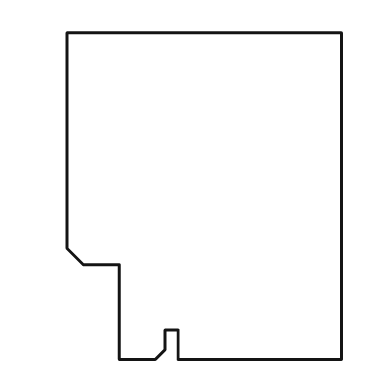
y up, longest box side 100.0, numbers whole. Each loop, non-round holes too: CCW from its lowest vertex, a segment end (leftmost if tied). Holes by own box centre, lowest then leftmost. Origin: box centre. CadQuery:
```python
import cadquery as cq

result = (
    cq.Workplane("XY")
    .moveTo(-26.0, -50.0)
    .lineTo(-15.0, -50.0)
    .lineTo(-12.0, -47.0)
    .lineTo(-12.0, -41.0)
    .lineTo(-8.0, -41.0)
    .lineTo(-8.0, -50.0)
    .lineTo(42.0, -50.0)
    .lineTo(42.0, 50.0)
    .lineTo(-42.0, 50.0)
    .lineTo(-42.0, -16.0)
    .lineTo(-37.0, -21.0)
    .lineTo(-26.0, -21.0)
    .close()
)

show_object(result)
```